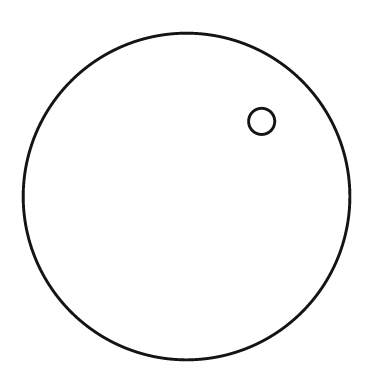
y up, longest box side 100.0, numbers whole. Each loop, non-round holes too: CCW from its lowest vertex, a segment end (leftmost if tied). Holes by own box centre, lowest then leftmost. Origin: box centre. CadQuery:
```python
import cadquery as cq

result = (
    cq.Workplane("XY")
    .moveTo(0.0, 0.0)
    .circle(50.0)
    .moveTo(23.0, 23.0)
    .circle(4.0)
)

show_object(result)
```